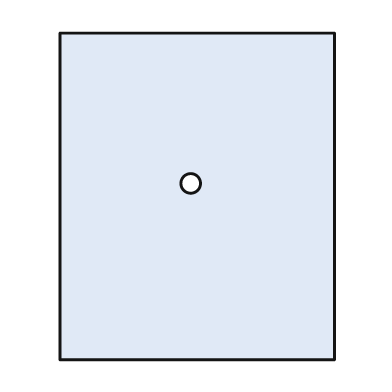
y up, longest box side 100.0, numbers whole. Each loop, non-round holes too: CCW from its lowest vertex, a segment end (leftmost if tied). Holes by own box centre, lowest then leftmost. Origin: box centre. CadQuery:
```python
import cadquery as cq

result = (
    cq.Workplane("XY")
    .moveTo(-42.0, -50.0)
    .lineTo(42.0, -50.0)
    .lineTo(42.0, 50.0)
    .lineTo(-42.0, 50.0)
    .close()
    .moveTo(-2.0, 4.0)
    .circle(3.0)
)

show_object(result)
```